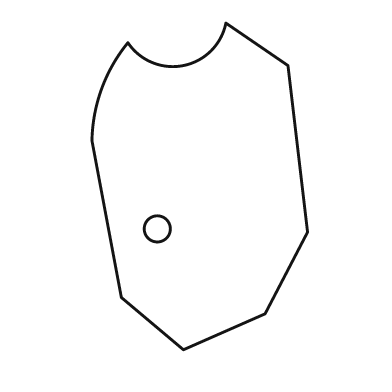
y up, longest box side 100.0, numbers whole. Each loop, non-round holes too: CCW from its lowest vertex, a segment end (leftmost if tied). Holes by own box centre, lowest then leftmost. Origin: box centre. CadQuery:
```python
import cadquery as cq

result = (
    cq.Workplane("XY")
    .moveTo(-5.0, -50.0)
    .lineTo(20.0, -39.0)
    .lineTo(33.0, -14.0)
    .lineTo(27.0, 37.0)
    .lineTo(8.0, 50.0)
    .threePointArc((-5.0, 37.0), (-22.0, 44.0))
    .threePointArc((-30.0, 30.0), (-33.0, 14.0))
    .lineTo(-24.0, -34.0)
    .close()
    .moveTo(-13.0, -13.0)
    .circle(4.0)
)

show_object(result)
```